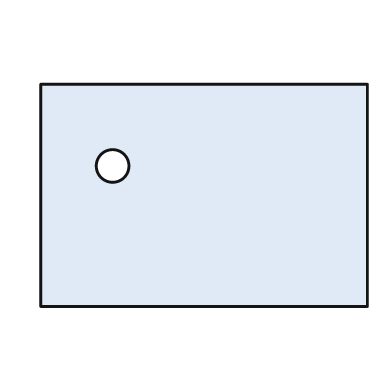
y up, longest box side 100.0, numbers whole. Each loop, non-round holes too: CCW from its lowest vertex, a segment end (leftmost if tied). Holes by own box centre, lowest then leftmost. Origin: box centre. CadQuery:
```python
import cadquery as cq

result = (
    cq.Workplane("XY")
    .moveTo(-50.0, -34.0)
    .lineTo(50.0, -34.0)
    .lineTo(50.0, 34.0)
    .lineTo(-50.0, 34.0)
    .close()
    .moveTo(-28.0, 9.0)
    .circle(5.0)
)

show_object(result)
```